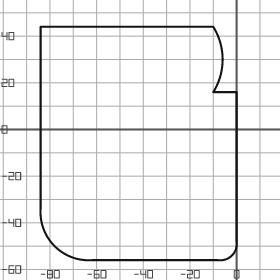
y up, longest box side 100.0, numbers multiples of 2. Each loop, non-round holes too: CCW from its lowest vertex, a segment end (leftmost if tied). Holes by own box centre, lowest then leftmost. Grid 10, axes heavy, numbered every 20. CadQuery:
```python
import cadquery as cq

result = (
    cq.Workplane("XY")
    .moveTo(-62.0, -56.0)
    .lineTo(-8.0, -56.0)
    .threePointArc((-2.0, -54.0), (0.0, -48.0))
    .lineTo(0.0, 16.0)
    .lineTo(-10.0, 16.0)
    .threePointArc((-6.0, 30.0), (-10.0, 44.0))
    .lineTo(-84.0, 44.0)
    .lineTo(-84.0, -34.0)
    .threePointArc((-78.0, -50.0), (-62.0, -56.0))
    .close()
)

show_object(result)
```